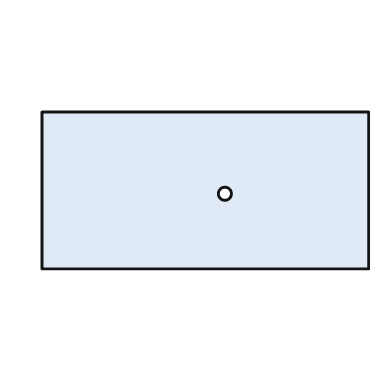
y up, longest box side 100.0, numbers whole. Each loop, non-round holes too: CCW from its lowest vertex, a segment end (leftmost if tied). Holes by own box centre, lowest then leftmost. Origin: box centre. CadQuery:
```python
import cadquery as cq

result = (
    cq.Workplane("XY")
    .moveTo(-50.0, -24.0)
    .lineTo(50.0, -24.0)
    .lineTo(50.0, 24.0)
    .lineTo(-50.0, 24.0)
    .close()
    .moveTo(6.0, -1.0)
    .circle(2.0)
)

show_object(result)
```